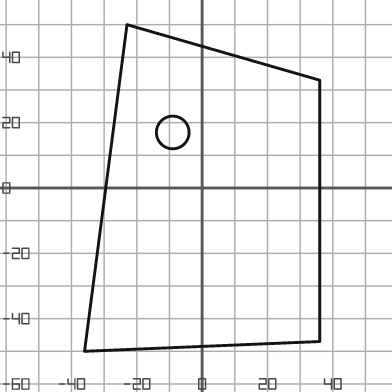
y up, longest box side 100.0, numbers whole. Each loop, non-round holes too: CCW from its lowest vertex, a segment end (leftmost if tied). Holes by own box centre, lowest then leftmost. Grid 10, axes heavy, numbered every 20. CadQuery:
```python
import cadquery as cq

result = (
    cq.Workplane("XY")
    .moveTo(-36.0, -50.0)
    .lineTo(36.0, -47.0)
    .lineTo(36.0, 33.0)
    .lineTo(-23.0, 50.0)
    .close()
    .moveTo(-9.0, 17.0)
    .circle(5.0)
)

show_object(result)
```